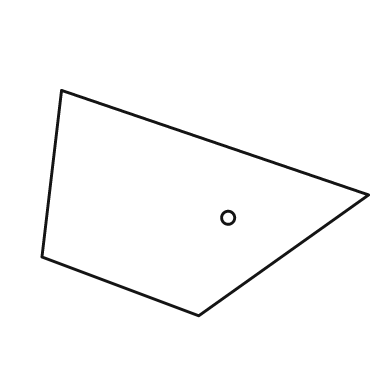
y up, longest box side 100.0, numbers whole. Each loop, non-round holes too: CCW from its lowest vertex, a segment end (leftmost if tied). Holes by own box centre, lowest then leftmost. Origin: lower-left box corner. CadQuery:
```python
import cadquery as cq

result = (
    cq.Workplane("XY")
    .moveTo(48.0, 0.0)
    .lineTo(100.0, 37.0)
    .lineTo(6.0, 69.0)
    .lineTo(0.0, 18.0)
    .close()
    .moveTo(57.0, 30.0)
    .circle(2.0)
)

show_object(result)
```